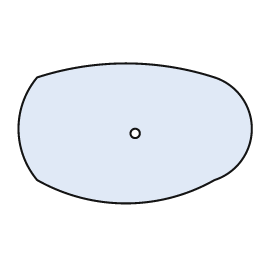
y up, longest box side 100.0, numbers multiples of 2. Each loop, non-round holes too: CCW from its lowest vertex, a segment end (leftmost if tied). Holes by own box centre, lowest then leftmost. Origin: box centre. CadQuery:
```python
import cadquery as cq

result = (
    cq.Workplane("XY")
    .moveTo(-42.0, -20.0)
    .threePointArc((-4.0, -30.0), (34.0, -20.0))
    .threePointArc((50.0, 2.0), (34.0, 24.0))
    .threePointArc((-4.0, 30.0), (-42.0, 24.0))
    .threePointArc((-50.0, 2.0), (-42.0, -20.0))
    .close()
    .moveTo(0.0, 0.0)
    .circle(2.0)
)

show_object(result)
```